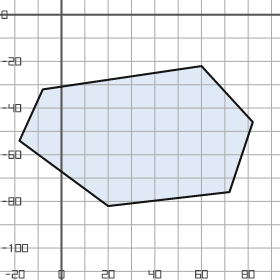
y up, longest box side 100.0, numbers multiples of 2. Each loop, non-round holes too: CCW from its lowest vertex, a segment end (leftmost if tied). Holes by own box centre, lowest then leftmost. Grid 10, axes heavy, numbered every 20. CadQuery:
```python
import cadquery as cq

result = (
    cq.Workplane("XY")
    .moveTo(20.0, -82.0)
    .lineTo(72.0, -76.0)
    .lineTo(82.0, -46.0)
    .lineTo(60.0, -22.0)
    .lineTo(-8.0, -32.0)
    .lineTo(-18.0, -54.0)
    .close()
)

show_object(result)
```